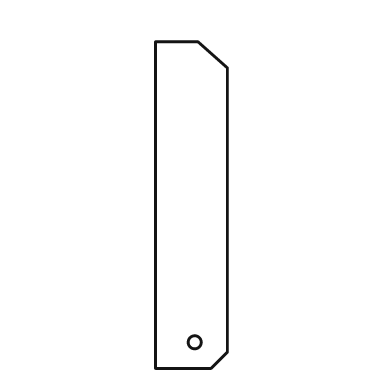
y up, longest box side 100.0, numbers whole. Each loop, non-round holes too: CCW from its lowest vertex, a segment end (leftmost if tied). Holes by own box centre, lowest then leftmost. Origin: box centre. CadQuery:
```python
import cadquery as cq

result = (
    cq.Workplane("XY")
    .moveTo(-11.0, -50.0)
    .lineTo(6.0, -50.0)
    .lineTo(11.0, -45.0)
    .lineTo(11.0, 42.0)
    .lineTo(2.0, 50.0)
    .lineTo(-11.0, 50.0)
    .close()
    .moveTo(1.0, -42.0)
    .circle(2.0)
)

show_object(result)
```